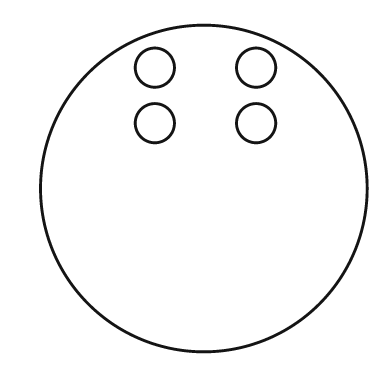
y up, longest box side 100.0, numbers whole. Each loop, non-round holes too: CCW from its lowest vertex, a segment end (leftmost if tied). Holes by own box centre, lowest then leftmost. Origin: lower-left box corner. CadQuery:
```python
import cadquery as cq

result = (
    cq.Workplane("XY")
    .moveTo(50.0, 50.0)
    .circle(50.0)
    .moveTo(35.0, 70.0)
    .circle(6.0)
    .moveTo(66.0, 70.0)
    .circle(6.0)
    .moveTo(35.0, 87.0)
    .circle(6.0)
    .moveTo(66.0, 87.0)
    .circle(6.0)
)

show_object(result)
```